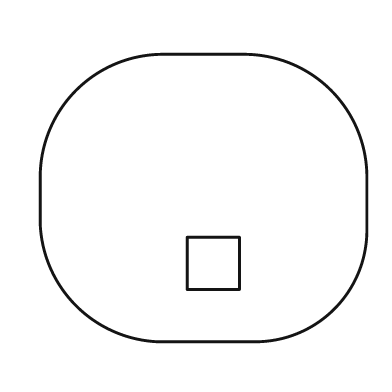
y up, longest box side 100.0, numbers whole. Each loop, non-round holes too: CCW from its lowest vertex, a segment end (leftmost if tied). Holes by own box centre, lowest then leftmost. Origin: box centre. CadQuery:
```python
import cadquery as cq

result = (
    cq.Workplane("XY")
    .moveTo(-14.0, -44.0)
    .lineTo(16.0, -44.0)
    .threePointArc((40.0, -34.0), (50.0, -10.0))
    .lineTo(50.0, 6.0)
    .threePointArc((39.0, 33.0), (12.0, 44.0))
    .lineTo(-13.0, 44.0)
    .threePointArc((-39.0, 33.0), (-50.0, 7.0))
    .lineTo(-50.0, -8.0)
    .threePointArc((-39.0, -33.0), (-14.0, -44.0))
    .close()
    .moveTo(-5.0, -28.0)
    .lineTo(11.0, -28.0)
    .lineTo(11.0, -12.0)
    .lineTo(-5.0, -12.0)
    .close()
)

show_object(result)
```